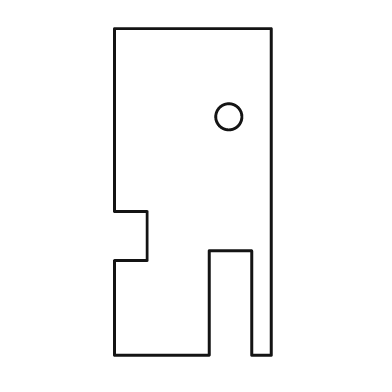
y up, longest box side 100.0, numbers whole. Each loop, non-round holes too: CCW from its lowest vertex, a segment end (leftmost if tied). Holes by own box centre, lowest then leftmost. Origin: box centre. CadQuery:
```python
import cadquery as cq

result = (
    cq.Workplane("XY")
    .moveTo(-24.0, -50.0)
    .lineTo(5.0, -50.0)
    .lineTo(5.0, -18.0)
    .lineTo(18.0, -18.0)
    .lineTo(18.0, -50.0)
    .lineTo(24.0, -50.0)
    .lineTo(24.0, 50.0)
    .lineTo(-24.0, 50.0)
    .lineTo(-24.0, -6.0)
    .lineTo(-14.0, -6.0)
    .lineTo(-14.0, -21.0)
    .lineTo(-24.0, -21.0)
    .close()
    .moveTo(11.0, 23.0)
    .circle(4.0)
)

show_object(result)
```